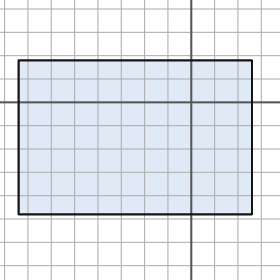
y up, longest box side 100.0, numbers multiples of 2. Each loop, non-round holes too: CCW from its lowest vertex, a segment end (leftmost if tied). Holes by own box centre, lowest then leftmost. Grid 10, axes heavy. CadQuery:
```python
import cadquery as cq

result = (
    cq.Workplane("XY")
    .moveTo(-74.0, -48.0)
    .lineTo(26.0, -48.0)
    .lineTo(26.0, 18.0)
    .lineTo(-74.0, 18.0)
    .close()
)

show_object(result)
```